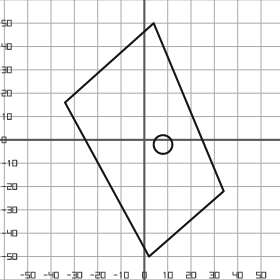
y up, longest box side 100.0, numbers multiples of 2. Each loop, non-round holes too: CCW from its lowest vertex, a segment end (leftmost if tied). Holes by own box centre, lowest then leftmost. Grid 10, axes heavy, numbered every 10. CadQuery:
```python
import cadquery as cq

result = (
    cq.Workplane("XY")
    .moveTo(2.0, -50.0)
    .lineTo(34.0, -22.0)
    .lineTo(4.0, 50.0)
    .lineTo(-34.0, 16.0)
    .close()
    .moveTo(8.0, -2.0)
    .circle(4.0)
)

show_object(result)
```